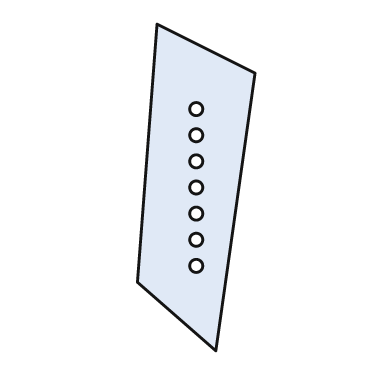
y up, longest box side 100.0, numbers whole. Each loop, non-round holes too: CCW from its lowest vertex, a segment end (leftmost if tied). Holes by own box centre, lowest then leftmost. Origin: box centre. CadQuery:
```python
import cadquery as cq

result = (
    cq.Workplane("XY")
    .moveTo(6.0, -50.0)
    .lineTo(18.0, 35.0)
    .lineTo(-12.0, 50.0)
    .lineTo(-18.0, -29.0)
    .close()
    .moveTo(0.0, -24.0)
    .circle(2.0)
    .moveTo(0.0, -16.0)
    .circle(2.0)
    .moveTo(0.0, -8.0)
    .circle(2.0)
    .moveTo(0.0, 0.0)
    .circle(2.0)
    .moveTo(0.0, 8.0)
    .circle(2.0)
    .moveTo(0.0, 16.0)
    .circle(2.0)
    .moveTo(0.0, 24.0)
    .circle(2.0)
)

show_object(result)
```